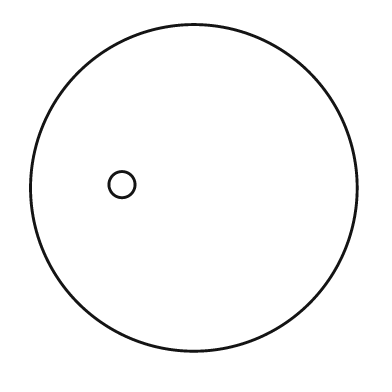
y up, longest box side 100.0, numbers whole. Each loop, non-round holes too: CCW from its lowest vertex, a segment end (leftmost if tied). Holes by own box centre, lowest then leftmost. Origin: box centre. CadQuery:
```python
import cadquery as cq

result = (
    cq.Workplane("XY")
    .moveTo(0.0, 0.0)
    .circle(50.0)
    .moveTo(-22.0, 1.0)
    .circle(4.0)
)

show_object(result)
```